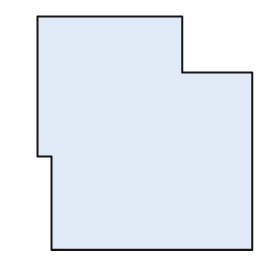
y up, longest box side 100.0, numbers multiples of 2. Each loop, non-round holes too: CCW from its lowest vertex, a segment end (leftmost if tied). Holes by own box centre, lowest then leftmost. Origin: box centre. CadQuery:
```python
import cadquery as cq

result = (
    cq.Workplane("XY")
    .moveTo(-40.0, -50.0)
    .lineTo(46.0, -50.0)
    .lineTo(46.0, 26.0)
    .lineTo(16.0, 26.0)
    .lineTo(16.0, 50.0)
    .lineTo(-46.0, 50.0)
    .lineTo(-46.0, -10.0)
    .lineTo(-40.0, -10.0)
    .close()
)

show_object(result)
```